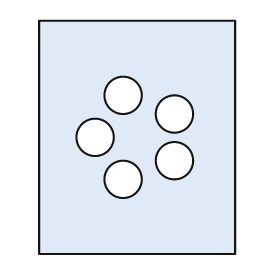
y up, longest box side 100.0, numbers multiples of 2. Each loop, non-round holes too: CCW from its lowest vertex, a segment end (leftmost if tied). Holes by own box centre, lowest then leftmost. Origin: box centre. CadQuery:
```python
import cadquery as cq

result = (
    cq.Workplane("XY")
    .moveTo(-42.0, -50.0)
    .lineTo(42.0, -50.0)
    .lineTo(42.0, 50.0)
    .lineTo(-42.0, 50.0)
    .close()
    .moveTo(-6.0, -18.0)
    .circle(8.0)
    .moveTo(16.0, -10.0)
    .circle(8.0)
    .moveTo(-18.0, 0.0)
    .circle(8.0)
    .moveTo(16.0, 10.0)
    .circle(8.0)
    .moveTo(-6.0, 18.0)
    .circle(8.0)
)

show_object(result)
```